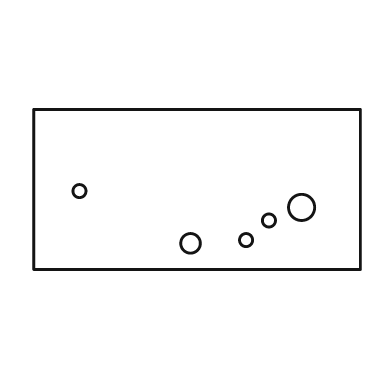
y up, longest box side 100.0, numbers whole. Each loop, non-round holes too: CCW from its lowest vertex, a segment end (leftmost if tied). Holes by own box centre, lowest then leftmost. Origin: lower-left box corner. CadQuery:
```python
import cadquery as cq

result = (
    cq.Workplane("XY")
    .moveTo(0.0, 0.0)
    .lineTo(100.0, 0.0)
    .lineTo(100.0, 49.0)
    .lineTo(0.0, 49.0)
    .close()
    .moveTo(48.0, 8.0)
    .circle(3.0)
    .moveTo(65.0, 9.0)
    .circle(2.0)
    .moveTo(72.0, 15.0)
    .circle(2.0)
    .moveTo(82.0, 19.0)
    .circle(4.0)
    .moveTo(14.0, 24.0)
    .circle(2.0)
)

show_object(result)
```